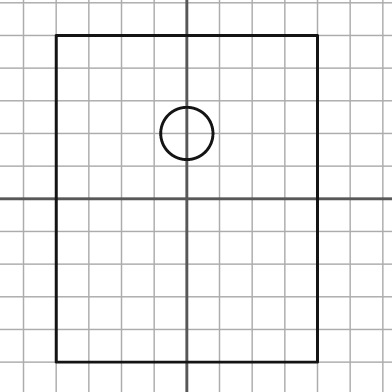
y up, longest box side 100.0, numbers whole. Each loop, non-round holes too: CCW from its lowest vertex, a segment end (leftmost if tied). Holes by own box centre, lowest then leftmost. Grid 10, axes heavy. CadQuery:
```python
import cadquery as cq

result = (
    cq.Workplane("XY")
    .moveTo(-40.0, -50.0)
    .lineTo(40.0, -50.0)
    .lineTo(40.0, 50.0)
    .lineTo(-40.0, 50.0)
    .close()
    .moveTo(0.0, 20.0)
    .circle(8.0)
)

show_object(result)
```